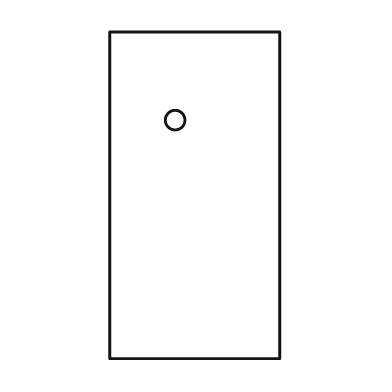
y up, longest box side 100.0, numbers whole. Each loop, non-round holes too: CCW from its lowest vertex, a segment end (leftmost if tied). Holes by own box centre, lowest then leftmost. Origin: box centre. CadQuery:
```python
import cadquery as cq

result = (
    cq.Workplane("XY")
    .moveTo(-26.0, -50.0)
    .lineTo(26.0, -50.0)
    .lineTo(26.0, 50.0)
    .lineTo(-26.0, 50.0)
    .close()
    .moveTo(-6.0, 23.0)
    .circle(3.0)
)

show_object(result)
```